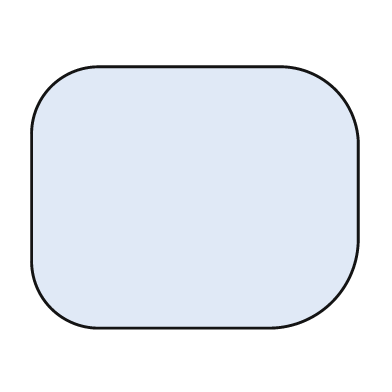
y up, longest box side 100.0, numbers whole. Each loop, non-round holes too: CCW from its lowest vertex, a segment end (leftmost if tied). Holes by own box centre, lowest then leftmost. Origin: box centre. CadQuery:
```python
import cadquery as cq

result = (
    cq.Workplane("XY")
    .moveTo(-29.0, -40.0)
    .lineTo(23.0, -40.0)
    .threePointArc((42.0, -32.0), (50.0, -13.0))
    .lineTo(50.0, 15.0)
    .threePointArc((43.0, 33.0), (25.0, 40.0))
    .lineTo(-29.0, 40.0)
    .threePointArc((-44.0, 34.0), (-50.0, 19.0))
    .lineTo(-50.0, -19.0)
    .threePointArc((-44.0, -34.0), (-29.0, -40.0))
    .close()
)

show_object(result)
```